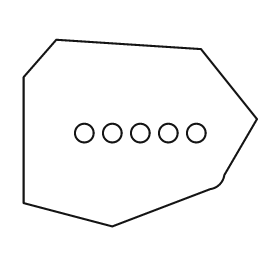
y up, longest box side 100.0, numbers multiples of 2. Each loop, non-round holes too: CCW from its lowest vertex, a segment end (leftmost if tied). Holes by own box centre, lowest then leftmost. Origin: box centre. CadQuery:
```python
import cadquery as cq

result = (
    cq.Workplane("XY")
    .moveTo(-12.0, -40.0)
    .lineTo(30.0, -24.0)
    .threePointArc((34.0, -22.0), (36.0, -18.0))
    .lineTo(50.0, 6.0)
    .lineTo(26.0, 36.0)
    .lineTo(-36.0, 40.0)
    .lineTo(-50.0, 24.0)
    .lineTo(-50.0, -30.0)
    .close()
    .moveTo(-24.0, 0.0)
    .circle(4.0)
    .moveTo(-12.0, 0.0)
    .circle(4.0)
    .moveTo(0.0, 0.0)
    .circle(4.0)
    .moveTo(12.0, 0.0)
    .circle(4.0)
    .moveTo(24.0, 0.0)
    .circle(4.0)
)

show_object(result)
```